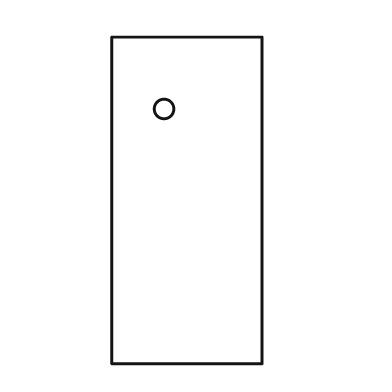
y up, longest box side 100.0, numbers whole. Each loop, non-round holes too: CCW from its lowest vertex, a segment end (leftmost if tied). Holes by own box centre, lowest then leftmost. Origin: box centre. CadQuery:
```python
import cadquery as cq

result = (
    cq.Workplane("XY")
    .moveTo(-23.0, -50.0)
    .lineTo(23.0, -50.0)
    .lineTo(23.0, 50.0)
    .lineTo(-23.0, 50.0)
    .close()
    .moveTo(-7.0, 28.0)
    .circle(3.0)
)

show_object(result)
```